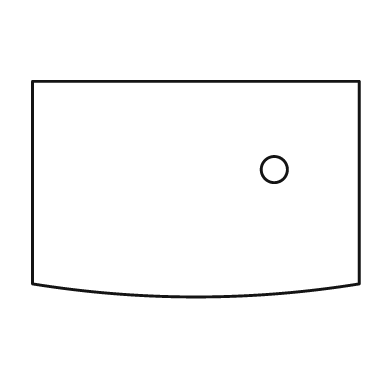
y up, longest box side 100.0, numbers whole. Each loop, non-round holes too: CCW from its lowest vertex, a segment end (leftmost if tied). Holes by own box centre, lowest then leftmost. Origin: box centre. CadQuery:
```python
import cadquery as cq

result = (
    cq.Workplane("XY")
    .moveTo(-50.0, -29.0)
    .threePointArc((0.0, -33.0), (50.0, -29.0))
    .lineTo(50.0, 33.0)
    .lineTo(-50.0, 33.0)
    .close()
    .moveTo(24.0, 6.0)
    .circle(4.0)
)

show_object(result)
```